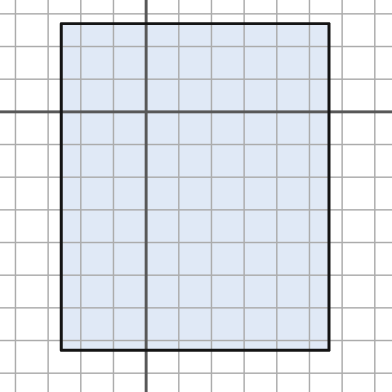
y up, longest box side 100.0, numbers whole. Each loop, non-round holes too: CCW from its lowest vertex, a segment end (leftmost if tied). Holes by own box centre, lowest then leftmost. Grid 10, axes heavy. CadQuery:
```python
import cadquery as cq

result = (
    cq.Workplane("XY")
    .moveTo(-26.0, -73.0)
    .lineTo(56.0, -73.0)
    .lineTo(56.0, 27.0)
    .lineTo(-26.0, 27.0)
    .close()
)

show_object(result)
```